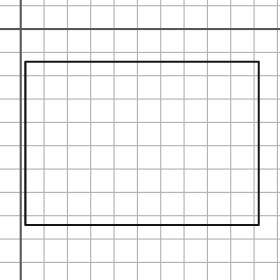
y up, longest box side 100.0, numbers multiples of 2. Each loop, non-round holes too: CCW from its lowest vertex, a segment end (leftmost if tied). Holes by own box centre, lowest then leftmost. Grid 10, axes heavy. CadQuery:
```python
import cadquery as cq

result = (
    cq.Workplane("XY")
    .moveTo(2.0, -84.0)
    .lineTo(102.0, -84.0)
    .lineTo(102.0, -14.0)
    .lineTo(2.0, -14.0)
    .close()
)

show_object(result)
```